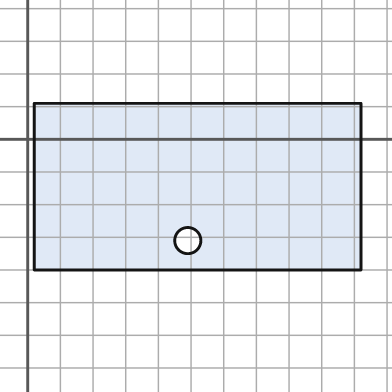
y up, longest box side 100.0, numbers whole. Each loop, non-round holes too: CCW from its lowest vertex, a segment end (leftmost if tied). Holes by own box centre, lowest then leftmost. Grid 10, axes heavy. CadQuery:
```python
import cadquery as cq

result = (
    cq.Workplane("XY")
    .moveTo(2.0, -40.0)
    .lineTo(102.0, -40.0)
    .lineTo(102.0, 11.0)
    .lineTo(2.0, 11.0)
    .close()
    .moveTo(49.0, -31.0)
    .circle(4.0)
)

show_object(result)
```